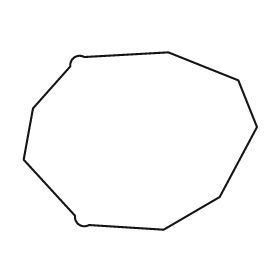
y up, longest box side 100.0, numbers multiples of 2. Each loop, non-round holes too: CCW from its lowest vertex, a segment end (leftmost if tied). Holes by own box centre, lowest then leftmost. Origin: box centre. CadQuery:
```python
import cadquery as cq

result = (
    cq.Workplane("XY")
    .moveTo(10.0, -38.0)
    .lineTo(34.0, -24.0)
    .lineTo(50.0, 6.0)
    .lineTo(42.0, 26.0)
    .lineTo(12.0, 38.0)
    .lineTo(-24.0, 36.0)
    .threePointArc((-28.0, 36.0), (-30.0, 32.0))
    .lineTo(-46.0, 14.0)
    .lineTo(-50.0, -8.0)
    .lineTo(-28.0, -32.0)
    .threePointArc((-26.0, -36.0), (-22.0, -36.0))
    .close()
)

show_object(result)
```